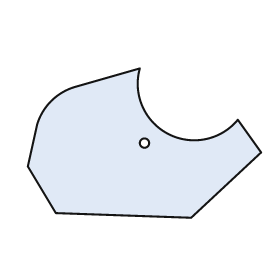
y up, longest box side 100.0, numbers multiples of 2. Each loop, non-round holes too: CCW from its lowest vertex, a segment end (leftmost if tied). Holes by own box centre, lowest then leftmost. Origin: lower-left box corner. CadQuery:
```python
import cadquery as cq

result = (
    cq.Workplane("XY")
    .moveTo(70.0, 0.0)
    .lineTo(100.0, 28.0)
    .lineTo(90.0, 42.0)
    .threePointArc((60.0, 36.0), (48.0, 64.0))
    .lineTo(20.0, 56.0)
    .threePointArc((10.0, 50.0), (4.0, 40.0))
    .lineTo(0.0, 22.0)
    .lineTo(12.0, 2.0)
    .close()
    .moveTo(50.0, 32.0)
    .circle(2.0)
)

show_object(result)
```